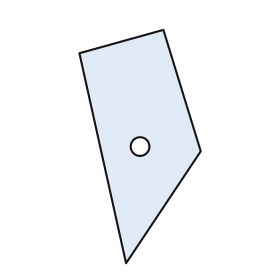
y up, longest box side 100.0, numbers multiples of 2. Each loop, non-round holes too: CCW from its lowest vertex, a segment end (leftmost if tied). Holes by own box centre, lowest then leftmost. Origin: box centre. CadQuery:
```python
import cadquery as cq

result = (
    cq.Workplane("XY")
    .moveTo(-6.0, -50.0)
    .lineTo(26.0, -2.0)
    .lineTo(10.0, 50.0)
    .lineTo(-26.0, 40.0)
    .close()
    .moveTo(0.0, 0.0)
    .circle(4.0)
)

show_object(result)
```